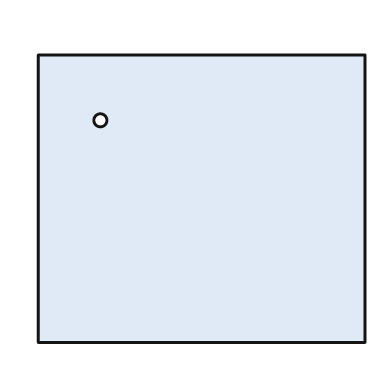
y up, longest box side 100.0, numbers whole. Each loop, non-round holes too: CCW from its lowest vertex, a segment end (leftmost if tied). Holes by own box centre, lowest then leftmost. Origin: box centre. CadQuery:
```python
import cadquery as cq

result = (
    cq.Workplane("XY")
    .moveTo(-50.0, -44.0)
    .lineTo(50.0, -44.0)
    .lineTo(50.0, 44.0)
    .lineTo(-50.0, 44.0)
    .close()
    .moveTo(-31.0, 24.0)
    .circle(2.0)
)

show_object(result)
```